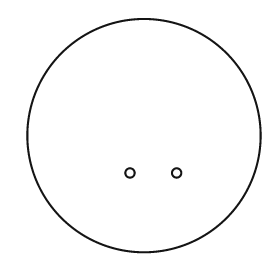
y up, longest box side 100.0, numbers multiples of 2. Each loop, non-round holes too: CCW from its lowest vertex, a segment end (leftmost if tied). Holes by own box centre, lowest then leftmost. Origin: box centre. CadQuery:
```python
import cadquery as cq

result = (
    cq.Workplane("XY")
    .moveTo(0.0, 0.0)
    .circle(50.0)
    .moveTo(-6.0, -16.0)
    .circle(2.0)
    .moveTo(14.0, -16.0)
    .circle(2.0)
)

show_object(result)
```